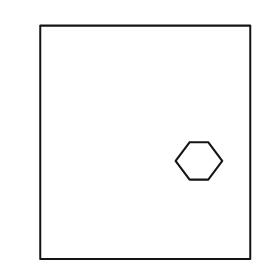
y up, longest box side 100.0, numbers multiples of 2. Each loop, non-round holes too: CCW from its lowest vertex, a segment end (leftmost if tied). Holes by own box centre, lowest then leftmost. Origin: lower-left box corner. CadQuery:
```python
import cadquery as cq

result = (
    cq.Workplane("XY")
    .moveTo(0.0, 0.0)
    .lineTo(90.0, 0.0)
    .lineTo(90.0, 100.0)
    .lineTo(0.0, 100.0)
    .close()
    .moveTo(64.0, 34.0)
    .lineTo(72.0, 34.0)
    .lineTo(78.0, 42.0)
    .lineTo(72.0, 50.0)
    .lineTo(64.0, 50.0)
    .lineTo(58.0, 42.0)
    .close()
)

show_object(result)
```